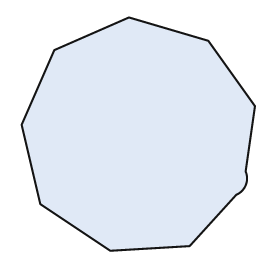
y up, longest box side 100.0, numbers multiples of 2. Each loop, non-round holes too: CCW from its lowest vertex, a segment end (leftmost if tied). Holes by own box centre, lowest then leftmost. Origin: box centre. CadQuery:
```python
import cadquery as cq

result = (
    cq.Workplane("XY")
    .moveTo(-12.0, -50.0)
    .lineTo(22.0, -48.0)
    .lineTo(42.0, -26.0)
    .threePointArc((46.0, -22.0), (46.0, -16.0))
    .lineTo(50.0, 12.0)
    .lineTo(30.0, 40.0)
    .lineTo(-4.0, 50.0)
    .lineTo(-36.0, 36.0)
    .lineTo(-50.0, 4.0)
    .lineTo(-42.0, -30.0)
    .close()
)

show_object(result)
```